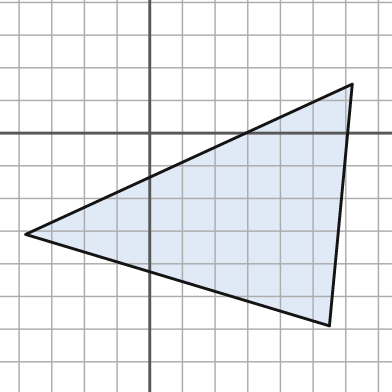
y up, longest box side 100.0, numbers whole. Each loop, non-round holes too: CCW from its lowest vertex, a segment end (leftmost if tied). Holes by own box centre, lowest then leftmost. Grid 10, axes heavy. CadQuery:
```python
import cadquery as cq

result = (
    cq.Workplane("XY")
    .moveTo(55.0, -59.0)
    .lineTo(62.0, 15.0)
    .lineTo(-38.0, -31.0)
    .close()
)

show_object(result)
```